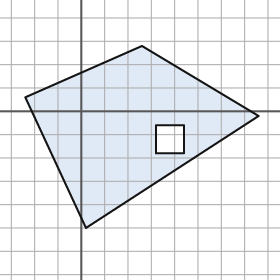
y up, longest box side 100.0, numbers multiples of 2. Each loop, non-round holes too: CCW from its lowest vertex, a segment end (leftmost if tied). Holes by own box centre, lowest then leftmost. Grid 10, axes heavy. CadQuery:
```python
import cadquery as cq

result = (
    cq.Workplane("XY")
    .moveTo(2.0, -50.0)
    .lineTo(76.0, -2.0)
    .lineTo(26.0, 28.0)
    .lineTo(-24.0, 6.0)
    .close()
    .moveTo(32.0, -18.0)
    .lineTo(44.0, -18.0)
    .lineTo(44.0, -6.0)
    .lineTo(32.0, -6.0)
    .close()
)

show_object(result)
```